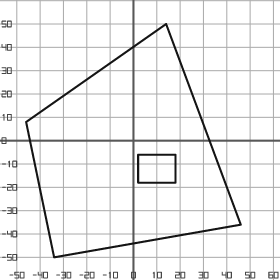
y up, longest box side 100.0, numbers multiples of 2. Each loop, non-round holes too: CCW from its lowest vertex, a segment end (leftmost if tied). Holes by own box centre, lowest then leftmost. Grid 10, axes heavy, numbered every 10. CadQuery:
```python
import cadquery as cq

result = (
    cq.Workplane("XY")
    .moveTo(-34.0, -50.0)
    .lineTo(46.0, -36.0)
    .lineTo(14.0, 50.0)
    .lineTo(-46.0, 8.0)
    .close()
    .moveTo(2.0, -18.0)
    .lineTo(18.0, -18.0)
    .lineTo(18.0, -6.0)
    .lineTo(2.0, -6.0)
    .close()
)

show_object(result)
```